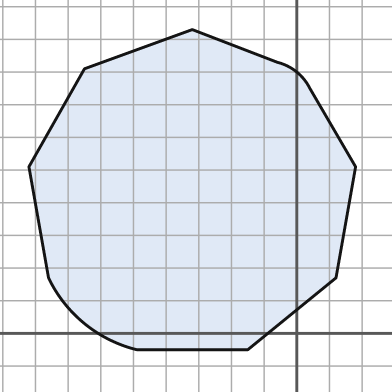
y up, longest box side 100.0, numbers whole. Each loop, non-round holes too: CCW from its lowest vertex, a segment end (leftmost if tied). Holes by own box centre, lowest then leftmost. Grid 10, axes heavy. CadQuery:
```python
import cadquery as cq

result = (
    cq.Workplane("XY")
    .moveTo(-49.0, -5.0)
    .lineTo(-15.0, -5.0)
    .lineTo(12.0, 17.0)
    .lineTo(18.0, 51.0)
    .lineTo(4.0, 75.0)
    .threePointArc((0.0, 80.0), (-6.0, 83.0))
    .lineTo(-32.0, 93.0)
    .lineTo(-65.0, 81.0)
    .lineTo(-82.0, 51.0)
    .lineTo(-76.0, 17.0)
    .threePointArc((-65.0, 3.0), (-49.0, -5.0))
    .close()
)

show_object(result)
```